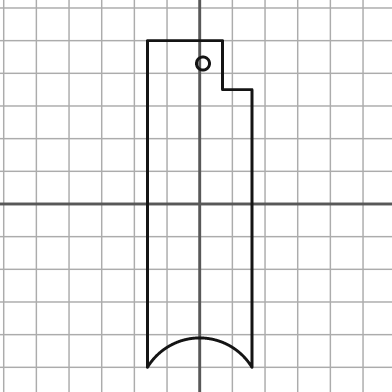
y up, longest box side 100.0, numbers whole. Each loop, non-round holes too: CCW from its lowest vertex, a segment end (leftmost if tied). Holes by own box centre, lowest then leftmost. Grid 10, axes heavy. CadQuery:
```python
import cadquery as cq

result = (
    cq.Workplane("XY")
    .moveTo(-16.0, -50.0)
    .threePointArc((0.0, -41.0), (16.0, -50.0))
    .lineTo(16.0, 35.0)
    .lineTo(7.0, 35.0)
    .lineTo(7.0, 50.0)
    .lineTo(-16.0, 50.0)
    .close()
    .moveTo(1.0, 43.0)
    .circle(2.0)
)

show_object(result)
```